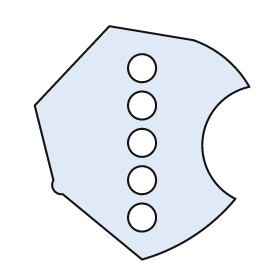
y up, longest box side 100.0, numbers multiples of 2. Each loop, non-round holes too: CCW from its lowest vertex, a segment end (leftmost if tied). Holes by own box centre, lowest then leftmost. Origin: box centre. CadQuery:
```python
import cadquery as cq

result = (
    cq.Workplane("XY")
    .moveTo(0.0, -50.0)
    .threePointArc((22.0, -40.0), (40.0, -24.0))
    .threePointArc((26.0, 2.0), (46.0, 24.0))
    .threePointArc((36.0, 36.0), (22.0, 44.0))
    .lineTo(-14.0, 50.0)
    .lineTo(-46.0, 16.0)
    .lineTo(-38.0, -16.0)
    .threePointArc((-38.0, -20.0), (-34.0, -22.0))
    .close()
    .moveTo(0.0, -32.0)
    .circle(6.0)
    .moveTo(0.0, -16.0)
    .circle(6.0)
    .moveTo(0.0, 0.0)
    .circle(6.0)
    .moveTo(0.0, 16.0)
    .circle(6.0)
    .moveTo(0.0, 32.0)
    .circle(6.0)
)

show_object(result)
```